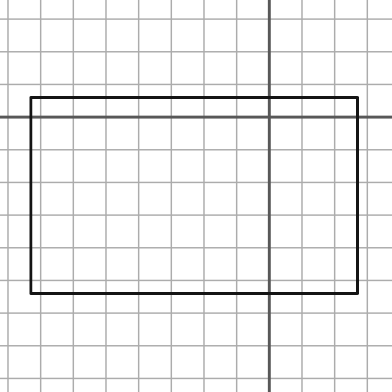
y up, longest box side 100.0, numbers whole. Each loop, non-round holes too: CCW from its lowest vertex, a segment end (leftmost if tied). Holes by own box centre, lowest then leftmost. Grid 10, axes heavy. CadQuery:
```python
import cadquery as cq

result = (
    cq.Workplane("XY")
    .moveTo(-73.0, -54.0)
    .lineTo(27.0, -54.0)
    .lineTo(27.0, 6.0)
    .lineTo(-73.0, 6.0)
    .close()
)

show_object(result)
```